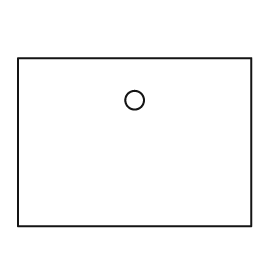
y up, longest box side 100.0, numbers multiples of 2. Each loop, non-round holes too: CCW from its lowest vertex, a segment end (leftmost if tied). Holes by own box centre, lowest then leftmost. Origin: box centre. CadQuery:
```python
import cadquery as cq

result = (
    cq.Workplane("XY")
    .moveTo(-50.0, -36.0)
    .lineTo(50.0, -36.0)
    .lineTo(50.0, 36.0)
    .lineTo(-50.0, 36.0)
    .close()
    .moveTo(0.0, 18.0)
    .circle(4.0)
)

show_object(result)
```